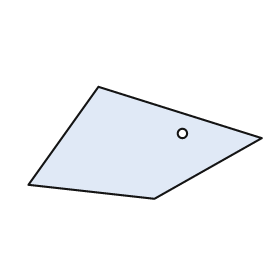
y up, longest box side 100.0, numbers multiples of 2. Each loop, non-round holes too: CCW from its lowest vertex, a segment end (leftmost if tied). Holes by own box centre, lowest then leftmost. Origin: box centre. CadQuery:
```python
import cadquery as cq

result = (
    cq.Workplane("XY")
    .moveTo(4.0, -24.0)
    .lineTo(50.0, 2.0)
    .lineTo(-20.0, 24.0)
    .lineTo(-50.0, -18.0)
    .close()
    .moveTo(16.0, 4.0)
    .circle(2.0)
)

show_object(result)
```